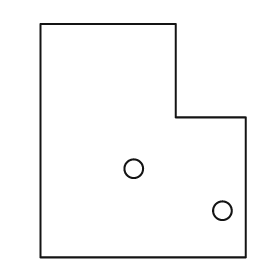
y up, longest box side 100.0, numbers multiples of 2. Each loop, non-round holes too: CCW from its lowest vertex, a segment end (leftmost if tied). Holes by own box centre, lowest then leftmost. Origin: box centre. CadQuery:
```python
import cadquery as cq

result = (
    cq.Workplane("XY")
    .moveTo(-44.0, -50.0)
    .lineTo(44.0, -50.0)
    .lineTo(44.0, 10.0)
    .lineTo(14.0, 10.0)
    .lineTo(14.0, 50.0)
    .lineTo(-44.0, 50.0)
    .close()
    .moveTo(34.0, -30.0)
    .circle(4.0)
    .moveTo(-4.0, -12.0)
    .circle(4.0)
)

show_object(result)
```